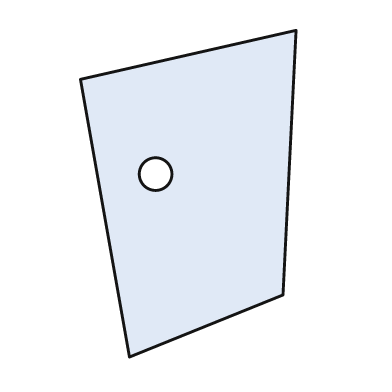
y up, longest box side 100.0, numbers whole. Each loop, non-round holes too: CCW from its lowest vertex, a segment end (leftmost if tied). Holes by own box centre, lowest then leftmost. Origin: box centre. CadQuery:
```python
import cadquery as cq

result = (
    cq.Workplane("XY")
    .moveTo(-18.0, -50.0)
    .lineTo(29.0, -31.0)
    .lineTo(33.0, 50.0)
    .lineTo(-33.0, 35.0)
    .close()
    .moveTo(-10.0, 6.0)
    .circle(5.0)
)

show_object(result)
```